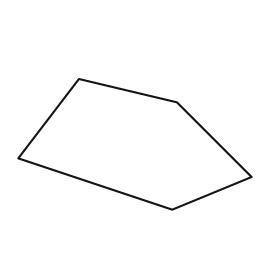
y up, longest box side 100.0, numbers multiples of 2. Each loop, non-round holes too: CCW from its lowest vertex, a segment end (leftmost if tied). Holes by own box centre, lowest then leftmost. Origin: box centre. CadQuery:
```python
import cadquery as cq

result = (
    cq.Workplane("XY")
    .moveTo(16.0, -28.0)
    .lineTo(50.0, -14.0)
    .lineTo(18.0, 18.0)
    .lineTo(-24.0, 28.0)
    .lineTo(-50.0, -6.0)
    .close()
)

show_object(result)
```